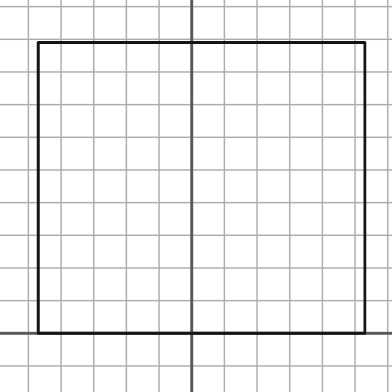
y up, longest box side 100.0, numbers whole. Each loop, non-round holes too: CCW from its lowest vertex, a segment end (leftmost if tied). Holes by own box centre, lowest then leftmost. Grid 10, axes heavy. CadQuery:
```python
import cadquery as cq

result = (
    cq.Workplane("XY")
    .moveTo(-47.0, 0.0)
    .lineTo(53.0, 0.0)
    .lineTo(53.0, 89.0)
    .lineTo(-47.0, 89.0)
    .close()
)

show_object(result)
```